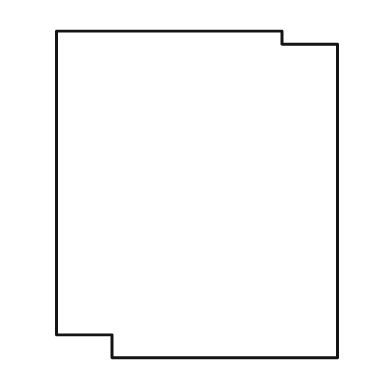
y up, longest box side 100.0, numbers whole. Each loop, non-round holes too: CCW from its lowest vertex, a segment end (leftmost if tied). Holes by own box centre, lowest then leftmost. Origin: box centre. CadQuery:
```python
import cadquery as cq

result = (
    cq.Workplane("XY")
    .moveTo(-26.0, -50.0)
    .lineTo(43.0, -50.0)
    .lineTo(43.0, 46.0)
    .lineTo(26.0, 46.0)
    .lineTo(26.0, 50.0)
    .lineTo(-43.0, 50.0)
    .lineTo(-43.0, -43.0)
    .lineTo(-26.0, -43.0)
    .close()
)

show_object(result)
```